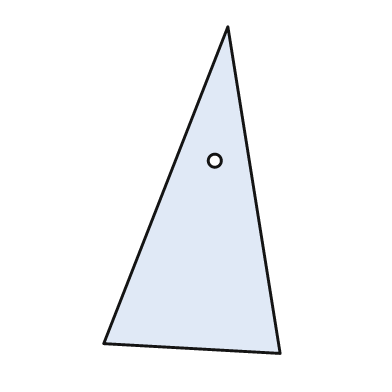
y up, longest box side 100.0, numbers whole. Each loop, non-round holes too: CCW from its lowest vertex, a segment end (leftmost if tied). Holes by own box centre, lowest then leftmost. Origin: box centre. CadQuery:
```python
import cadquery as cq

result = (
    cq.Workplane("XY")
    .moveTo(27.0, -50.0)
    .lineTo(11.0, 50.0)
    .lineTo(-27.0, -47.0)
    .close()
    .moveTo(7.0, 9.0)
    .circle(2.0)
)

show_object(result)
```